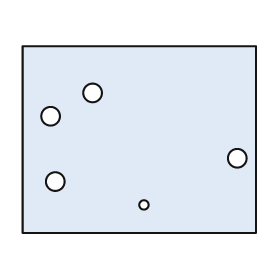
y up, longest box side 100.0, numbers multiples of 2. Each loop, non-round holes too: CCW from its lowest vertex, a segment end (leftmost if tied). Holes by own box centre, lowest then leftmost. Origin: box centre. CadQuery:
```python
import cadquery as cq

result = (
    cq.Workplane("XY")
    .moveTo(-50.0, -40.0)
    .lineTo(50.0, -40.0)
    .lineTo(50.0, 40.0)
    .lineTo(-50.0, 40.0)
    .close()
    .moveTo(2.0, -28.0)
    .circle(2.0)
    .moveTo(-36.0, -18.0)
    .circle(4.0)
    .moveTo(42.0, -8.0)
    .circle(4.0)
    .moveTo(-38.0, 10.0)
    .circle(4.0)
    .moveTo(-20.0, 20.0)
    .circle(4.0)
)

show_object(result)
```